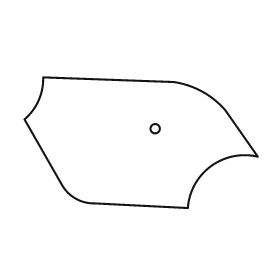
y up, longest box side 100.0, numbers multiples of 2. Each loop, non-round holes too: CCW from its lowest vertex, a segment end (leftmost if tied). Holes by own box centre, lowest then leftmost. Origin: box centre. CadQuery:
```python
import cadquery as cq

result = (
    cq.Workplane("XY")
    .moveTo(20.0, -28.0)
    .threePointArc((30.0, -10.0), (50.0, -6.0))
    .lineTo(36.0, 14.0)
    .threePointArc((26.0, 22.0), (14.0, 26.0))
    .lineTo(-42.0, 28.0)
    .threePointArc((-44.0, 18.0), (-50.0, 10.0))
    .lineTo(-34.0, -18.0)
    .threePointArc((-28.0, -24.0), (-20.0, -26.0))
    .close()
    .moveTo(6.0, 6.0)
    .circle(2.0)
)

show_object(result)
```